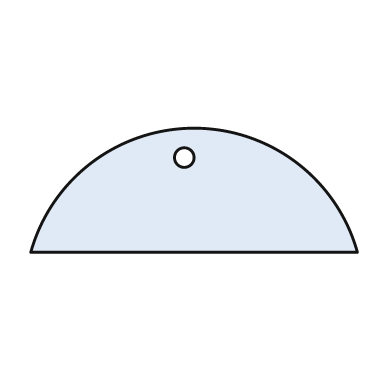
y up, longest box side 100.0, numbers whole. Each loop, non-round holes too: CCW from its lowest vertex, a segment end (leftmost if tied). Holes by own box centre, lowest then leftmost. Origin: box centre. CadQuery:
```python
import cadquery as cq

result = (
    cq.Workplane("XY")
    .moveTo(-50.0, -19.0)
    .lineTo(50.0, -19.0)
    .threePointArc((0.0, 19.0), (-50.0, -19.0))
    .close()
    .moveTo(-3.0, 10.0)
    .circle(3.0)
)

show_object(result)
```